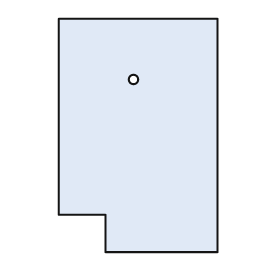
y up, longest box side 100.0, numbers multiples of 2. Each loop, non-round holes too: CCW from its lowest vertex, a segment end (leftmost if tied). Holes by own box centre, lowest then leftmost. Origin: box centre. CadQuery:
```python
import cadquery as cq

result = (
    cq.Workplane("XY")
    .moveTo(-14.0, -50.0)
    .lineTo(34.0, -50.0)
    .lineTo(34.0, 50.0)
    .lineTo(-34.0, 50.0)
    .lineTo(-34.0, -34.0)
    .lineTo(-14.0, -34.0)
    .close()
    .moveTo(-2.0, 24.0)
    .circle(2.0)
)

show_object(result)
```